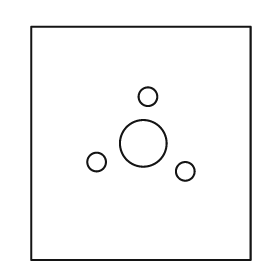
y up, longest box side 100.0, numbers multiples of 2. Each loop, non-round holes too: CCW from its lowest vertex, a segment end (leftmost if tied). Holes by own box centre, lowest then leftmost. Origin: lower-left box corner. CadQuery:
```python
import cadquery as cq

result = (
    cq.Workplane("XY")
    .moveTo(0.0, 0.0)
    .lineTo(94.0, 0.0)
    .lineTo(94.0, 100.0)
    .lineTo(0.0, 100.0)
    .close()
    .moveTo(66.0, 38.0)
    .circle(4.0)
    .moveTo(28.0, 42.0)
    .circle(4.0)
    .moveTo(48.0, 50.0)
    .circle(10.0)
    .moveTo(50.0, 70.0)
    .circle(4.0)
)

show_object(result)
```